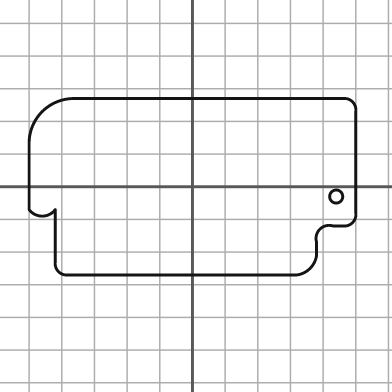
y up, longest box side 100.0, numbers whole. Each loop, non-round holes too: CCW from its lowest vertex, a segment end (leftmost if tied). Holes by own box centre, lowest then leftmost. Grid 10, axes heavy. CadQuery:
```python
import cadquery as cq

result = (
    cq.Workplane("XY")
    .moveTo(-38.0, -27.0)
    .lineTo(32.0, -27.0)
    .threePointArc((36.0, -25.0), (38.0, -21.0))
    .lineTo(38.0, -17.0)
    .threePointArc((39.0, -13.0), (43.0, -12.0))
    .lineTo(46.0, -12.0)
    .threePointArc((49.0, -11.0), (50.0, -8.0))
    .lineTo(50.0, 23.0)
    .threePointArc((49.0, 26.0), (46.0, 27.0))
    .lineTo(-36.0, 27.0)
    .threePointArc((-46.0, 23.0), (-50.0, 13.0))
    .lineTo(-50.0, -7.0)
    .threePointArc((-46.0, -9.0), (-42.0, -7.0))
    .lineTo(-42.0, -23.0)
    .threePointArc((-41.0, -26.0), (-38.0, -27.0))
    .close()
    .moveTo(44.0, -3.0)
    .circle(2.0)
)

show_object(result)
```